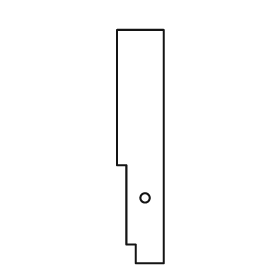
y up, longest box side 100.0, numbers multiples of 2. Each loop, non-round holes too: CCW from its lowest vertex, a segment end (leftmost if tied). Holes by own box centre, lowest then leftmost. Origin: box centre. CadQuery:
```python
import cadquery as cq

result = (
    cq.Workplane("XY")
    .moveTo(-2.0, -50.0)
    .lineTo(10.0, -50.0)
    .lineTo(10.0, 50.0)
    .lineTo(-10.0, 50.0)
    .lineTo(-10.0, -8.0)
    .lineTo(-6.0, -8.0)
    .lineTo(-6.0, -42.0)
    .lineTo(-2.0, -42.0)
    .close()
    .moveTo(2.0, -22.0)
    .circle(2.0)
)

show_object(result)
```